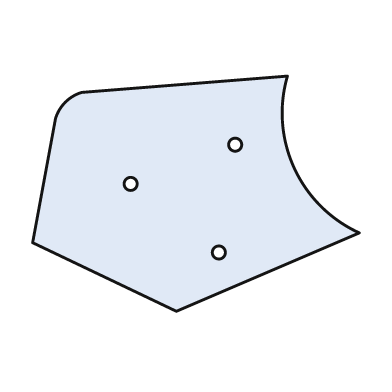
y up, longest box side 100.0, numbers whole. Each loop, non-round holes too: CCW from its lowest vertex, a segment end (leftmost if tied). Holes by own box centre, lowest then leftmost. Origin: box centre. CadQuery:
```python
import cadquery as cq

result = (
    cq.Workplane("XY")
    .moveTo(-6.0, -36.0)
    .lineTo(50.0, -12.0)
    .threePointArc((30.0, 8.0), (28.0, 36.0))
    .lineTo(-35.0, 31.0)
    .threePointArc((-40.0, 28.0), (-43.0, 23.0))
    .lineTo(-50.0, -15.0)
    .close()
    .moveTo(7.0, -18.0)
    .circle(2.0)
    .moveTo(-20.0, 3.0)
    .circle(2.0)
    .moveTo(12.0, 15.0)
    .circle(2.0)
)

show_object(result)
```